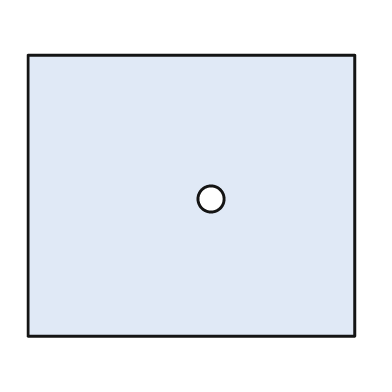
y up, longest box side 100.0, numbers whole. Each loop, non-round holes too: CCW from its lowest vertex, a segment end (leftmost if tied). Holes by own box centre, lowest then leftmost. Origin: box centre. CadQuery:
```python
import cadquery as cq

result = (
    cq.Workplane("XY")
    .moveTo(-50.0, -43.0)
    .lineTo(50.0, -43.0)
    .lineTo(50.0, 43.0)
    .lineTo(-50.0, 43.0)
    .close()
    .moveTo(6.0, -1.0)
    .circle(4.0)
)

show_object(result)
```